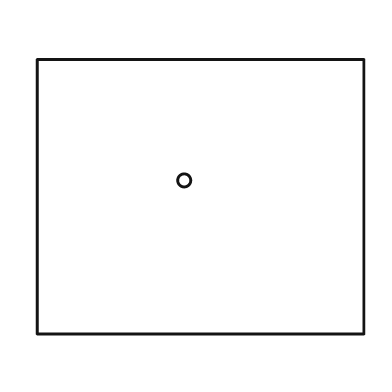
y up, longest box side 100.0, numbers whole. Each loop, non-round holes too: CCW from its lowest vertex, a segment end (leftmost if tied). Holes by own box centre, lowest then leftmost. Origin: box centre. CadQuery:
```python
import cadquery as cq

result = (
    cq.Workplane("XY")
    .moveTo(-50.0, -42.0)
    .lineTo(50.0, -42.0)
    .lineTo(50.0, 42.0)
    .lineTo(-50.0, 42.0)
    .close()
    .moveTo(-5.0, 5.0)
    .circle(2.0)
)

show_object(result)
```